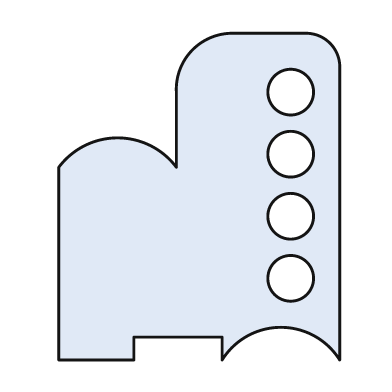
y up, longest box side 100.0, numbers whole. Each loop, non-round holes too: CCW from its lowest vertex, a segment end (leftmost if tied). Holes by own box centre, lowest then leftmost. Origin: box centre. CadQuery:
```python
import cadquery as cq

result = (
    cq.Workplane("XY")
    .moveTo(-43.0, -50.0)
    .lineTo(-20.0, -50.0)
    .lineTo(-20.0, -43.0)
    .lineTo(7.0, -43.0)
    .lineTo(7.0, -50.0)
    .threePointArc((25.0, -40.0), (43.0, -50.0))
    .lineTo(43.0, 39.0)
    .threePointArc((40.0, 47.0), (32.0, 50.0))
    .lineTo(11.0, 50.0)
    .threePointArc((-2.0, 45.0), (-7.0, 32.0))
    .lineTo(-7.0, 9.0)
    .threePointArc((-25.0, 18.0), (-43.0, 9.0))
    .close()
    .moveTo(28.0, -25.0)
    .circle(7.0)
    .moveTo(28.0, -6.0)
    .circle(7.0)
    .moveTo(28.0, 13.0)
    .circle(7.0)
    .moveTo(28.0, 32.0)
    .circle(7.0)
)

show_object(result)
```